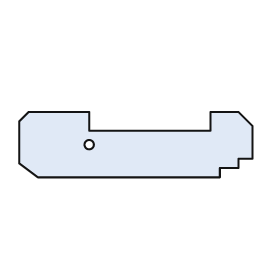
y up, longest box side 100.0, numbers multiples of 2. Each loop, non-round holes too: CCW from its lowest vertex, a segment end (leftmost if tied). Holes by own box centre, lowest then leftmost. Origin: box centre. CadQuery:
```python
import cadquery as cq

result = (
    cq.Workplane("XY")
    .moveTo(-42.0, -14.0)
    .lineTo(36.0, -14.0)
    .lineTo(36.0, -10.0)
    .lineTo(44.0, -10.0)
    .lineTo(44.0, -6.0)
    .lineTo(50.0, -6.0)
    .lineTo(50.0, 8.0)
    .lineTo(44.0, 14.0)
    .lineTo(32.0, 14.0)
    .lineTo(32.0, 6.0)
    .lineTo(-20.0, 6.0)
    .lineTo(-20.0, 14.0)
    .lineTo(-46.0, 14.0)
    .lineTo(-50.0, 10.0)
    .lineTo(-50.0, -8.0)
    .close()
    .moveTo(-20.0, 0.0)
    .circle(2.0)
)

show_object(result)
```